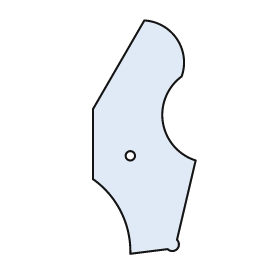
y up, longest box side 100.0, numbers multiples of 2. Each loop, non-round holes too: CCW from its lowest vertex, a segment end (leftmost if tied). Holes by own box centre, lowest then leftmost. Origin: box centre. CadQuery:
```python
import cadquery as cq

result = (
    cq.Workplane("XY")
    .moveTo(-6.0, -50.0)
    .lineTo(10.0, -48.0)
    .threePointArc((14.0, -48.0), (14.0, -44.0))
    .lineTo(22.0, -10.0)
    .threePointArc((8.0, 6.0), (16.0, 26.0))
    .threePointArc((14.0, 42.0), (0.0, 50.0))
    .lineTo(-22.0, 12.0)
    .lineTo(-22.0, -18.0)
    .threePointArc((-10.0, -32.0), (-6.0, -50.0))
    .close()
    .moveTo(-6.0, -8.0)
    .circle(2.0)
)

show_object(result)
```